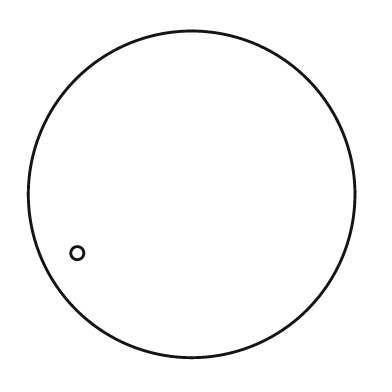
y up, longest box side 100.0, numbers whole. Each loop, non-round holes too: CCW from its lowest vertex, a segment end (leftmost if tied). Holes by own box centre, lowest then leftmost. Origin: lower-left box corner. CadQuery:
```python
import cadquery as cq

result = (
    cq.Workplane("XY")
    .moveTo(50.0, 50.0)
    .circle(50.0)
    .moveTo(15.0, 32.0)
    .circle(2.0)
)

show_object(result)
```